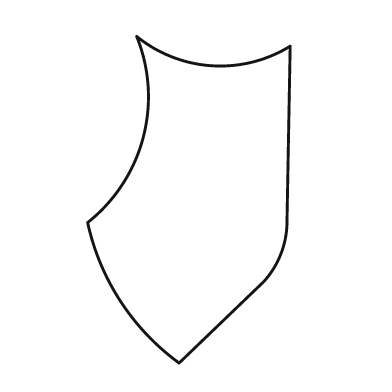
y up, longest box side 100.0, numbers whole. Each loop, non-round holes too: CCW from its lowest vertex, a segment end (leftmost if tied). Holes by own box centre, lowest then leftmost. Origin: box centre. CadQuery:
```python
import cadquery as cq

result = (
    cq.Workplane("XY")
    .moveTo(-3.0, -50.0)
    .lineTo(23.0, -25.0)
    .threePointArc((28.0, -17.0), (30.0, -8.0))
    .lineTo(31.0, 47.0)
    .threePointArc((7.0, 41.0), (-16.0, 50.0))
    .threePointArc((-14.0, 19.0), (-31.0, -7.0))
    .threePointArc((-21.0, -31.0), (-3.0, -50.0))
    .close()
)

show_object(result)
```